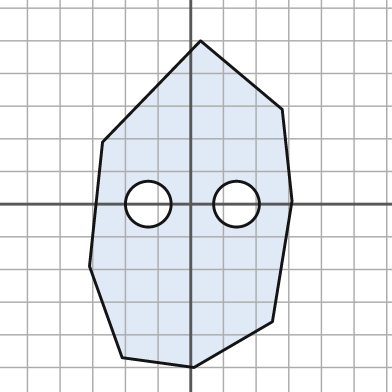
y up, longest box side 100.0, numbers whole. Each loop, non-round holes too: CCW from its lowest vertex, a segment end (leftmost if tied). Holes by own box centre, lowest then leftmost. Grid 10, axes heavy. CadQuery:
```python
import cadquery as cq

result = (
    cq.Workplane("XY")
    .moveTo(1.0, -50.0)
    .lineTo(25.0, -36.0)
    .lineTo(31.0, 1.0)
    .lineTo(28.0, 29.0)
    .lineTo(3.0, 50.0)
    .lineTo(-27.0, 19.0)
    .lineTo(-31.0, -19.0)
    .lineTo(-21.0, -47.0)
    .close()
    .moveTo(-13.0, 0.0)
    .circle(7.0)
    .moveTo(14.0, 0.0)
    .circle(7.0)
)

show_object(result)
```